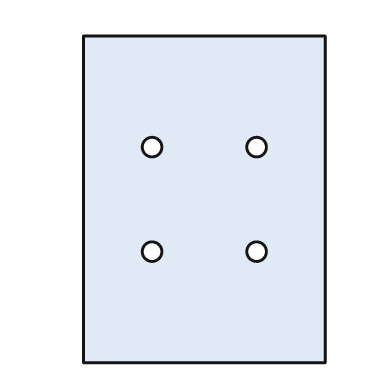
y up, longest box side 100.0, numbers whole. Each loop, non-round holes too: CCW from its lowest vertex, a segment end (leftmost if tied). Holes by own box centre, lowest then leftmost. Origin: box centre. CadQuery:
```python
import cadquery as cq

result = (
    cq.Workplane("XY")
    .moveTo(-37.0, -50.0)
    .lineTo(37.0, -50.0)
    .lineTo(37.0, 50.0)
    .lineTo(-37.0, 50.0)
    .close()
    .moveTo(-16.0, -16.0)
    .circle(3.0)
    .moveTo(16.0, -16.0)
    .circle(3.0)
    .moveTo(-16.0, 16.0)
    .circle(3.0)
    .moveTo(16.0, 16.0)
    .circle(3.0)
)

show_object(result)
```